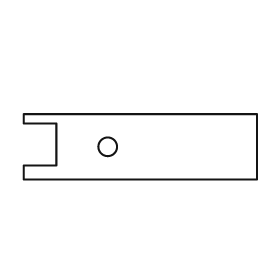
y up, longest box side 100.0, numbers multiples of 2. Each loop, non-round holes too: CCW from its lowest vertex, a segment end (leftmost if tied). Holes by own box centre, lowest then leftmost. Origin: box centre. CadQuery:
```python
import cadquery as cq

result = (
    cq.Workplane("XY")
    .moveTo(-50.0, -14.0)
    .lineTo(50.0, -14.0)
    .lineTo(50.0, 14.0)
    .lineTo(-50.0, 14.0)
    .lineTo(-50.0, 10.0)
    .lineTo(-36.0, 10.0)
    .lineTo(-36.0, -8.0)
    .lineTo(-50.0, -8.0)
    .close()
    .moveTo(-14.0, 0.0)
    .circle(4.0)
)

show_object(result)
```